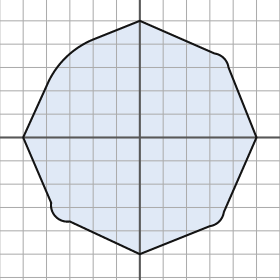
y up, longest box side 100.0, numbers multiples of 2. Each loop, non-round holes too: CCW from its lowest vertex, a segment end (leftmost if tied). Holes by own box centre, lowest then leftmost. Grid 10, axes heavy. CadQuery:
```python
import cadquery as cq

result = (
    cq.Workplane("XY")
    .moveTo(0.0, -50.0)
    .lineTo(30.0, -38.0)
    .threePointArc((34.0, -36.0), (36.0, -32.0))
    .lineTo(50.0, 0.0)
    .lineTo(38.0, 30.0)
    .threePointArc((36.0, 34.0), (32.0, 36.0))
    .lineTo(0.0, 50.0)
    .lineTo(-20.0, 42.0)
    .threePointArc((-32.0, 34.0), (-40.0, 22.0))
    .lineTo(-50.0, 0.0)
    .lineTo(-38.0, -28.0)
    .threePointArc((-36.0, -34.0), (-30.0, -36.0))
    .close()
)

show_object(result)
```